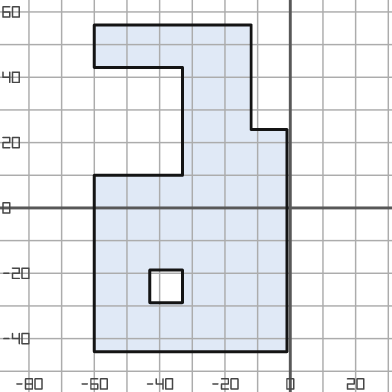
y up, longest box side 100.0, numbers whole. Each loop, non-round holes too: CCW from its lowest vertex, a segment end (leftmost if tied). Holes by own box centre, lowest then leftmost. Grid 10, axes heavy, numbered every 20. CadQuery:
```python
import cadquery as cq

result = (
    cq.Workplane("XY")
    .moveTo(-60.0, -44.0)
    .lineTo(-1.0, -44.0)
    .lineTo(-1.0, 24.0)
    .lineTo(-12.0, 24.0)
    .lineTo(-12.0, 56.0)
    .lineTo(-60.0, 56.0)
    .lineTo(-60.0, 43.0)
    .lineTo(-33.0, 43.0)
    .lineTo(-33.0, 10.0)
    .lineTo(-60.0, 10.0)
    .close()
    .moveTo(-43.0, -29.0)
    .lineTo(-33.0, -29.0)
    .lineTo(-33.0, -19.0)
    .lineTo(-43.0, -19.0)
    .close()
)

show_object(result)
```